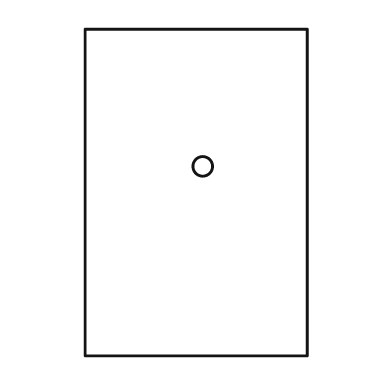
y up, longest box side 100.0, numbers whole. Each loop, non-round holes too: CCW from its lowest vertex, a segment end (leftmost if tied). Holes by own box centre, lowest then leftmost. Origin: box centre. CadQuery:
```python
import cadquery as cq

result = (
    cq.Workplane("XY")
    .moveTo(-34.0, -50.0)
    .lineTo(34.0, -50.0)
    .lineTo(34.0, 50.0)
    .lineTo(-34.0, 50.0)
    .close()
    .moveTo(2.0, 8.0)
    .circle(3.0)
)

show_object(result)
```